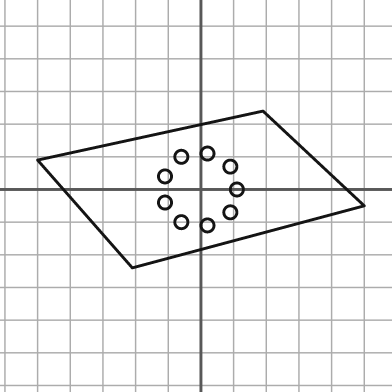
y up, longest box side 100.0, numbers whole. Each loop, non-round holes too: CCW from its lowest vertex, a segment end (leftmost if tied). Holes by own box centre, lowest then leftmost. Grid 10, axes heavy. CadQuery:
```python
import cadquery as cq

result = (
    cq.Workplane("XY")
    .moveTo(-21.0, -24.0)
    .lineTo(50.0, -5.0)
    .lineTo(19.0, 24.0)
    .lineTo(-50.0, 9.0)
    .close()
    .moveTo(2.0, -11.0)
    .circle(2.0)
    .moveTo(-6.0, -10.0)
    .circle(2.0)
    .moveTo(9.0, -7.0)
    .circle(2.0)
    .moveTo(-11.0, -4.0)
    .circle(2.0)
    .moveTo(11.0, 0.0)
    .circle(2.0)
    .moveTo(-11.0, 4.0)
    .circle(2.0)
    .moveTo(9.0, 7.0)
    .circle(2.0)
    .moveTo(-6.0, 10.0)
    .circle(2.0)
    .moveTo(2.0, 11.0)
    .circle(2.0)
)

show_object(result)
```